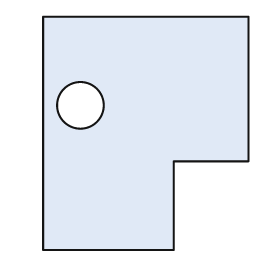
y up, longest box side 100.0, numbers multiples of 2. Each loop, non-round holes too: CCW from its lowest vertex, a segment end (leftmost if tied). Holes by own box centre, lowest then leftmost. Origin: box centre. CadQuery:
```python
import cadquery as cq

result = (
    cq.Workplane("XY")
    .moveTo(-44.0, -50.0)
    .lineTo(12.0, -50.0)
    .lineTo(12.0, -12.0)
    .lineTo(44.0, -12.0)
    .lineTo(44.0, 50.0)
    .lineTo(-44.0, 50.0)
    .close()
    .moveTo(-28.0, 12.0)
    .circle(10.0)
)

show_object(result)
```